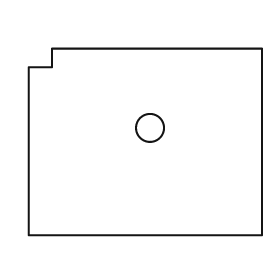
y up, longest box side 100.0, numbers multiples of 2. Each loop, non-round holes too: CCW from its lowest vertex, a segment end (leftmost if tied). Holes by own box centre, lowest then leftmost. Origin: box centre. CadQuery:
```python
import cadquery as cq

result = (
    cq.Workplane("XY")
    .moveTo(-50.0, -40.0)
    .lineTo(50.0, -40.0)
    .lineTo(50.0, 40.0)
    .lineTo(-40.0, 40.0)
    .lineTo(-40.0, 32.0)
    .lineTo(-50.0, 32.0)
    .close()
    .moveTo(2.0, 6.0)
    .circle(6.0)
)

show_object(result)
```